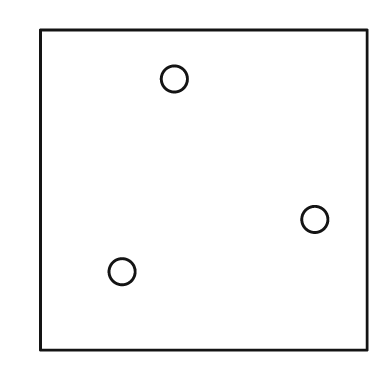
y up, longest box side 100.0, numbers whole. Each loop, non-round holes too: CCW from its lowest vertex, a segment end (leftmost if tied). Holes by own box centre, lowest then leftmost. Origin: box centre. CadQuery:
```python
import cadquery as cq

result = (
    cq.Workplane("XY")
    .moveTo(-50.0, -49.0)
    .lineTo(50.0, -49.0)
    .lineTo(50.0, 49.0)
    .lineTo(-50.0, 49.0)
    .close()
    .moveTo(-25.0, -25.0)
    .circle(4.0)
    .moveTo(34.0, -9.0)
    .circle(4.0)
    .moveTo(-9.0, 34.0)
    .circle(4.0)
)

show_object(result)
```